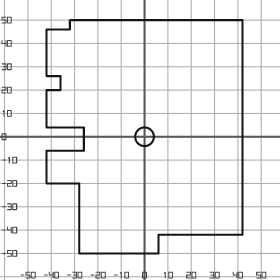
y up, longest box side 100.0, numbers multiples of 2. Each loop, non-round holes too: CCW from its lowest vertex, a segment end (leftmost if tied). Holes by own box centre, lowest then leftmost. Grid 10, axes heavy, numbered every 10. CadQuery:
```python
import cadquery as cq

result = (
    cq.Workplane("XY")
    .moveTo(-28.0, -50.0)
    .lineTo(6.0, -50.0)
    .lineTo(6.0, -42.0)
    .lineTo(42.0, -42.0)
    .lineTo(42.0, 50.0)
    .lineTo(-32.0, 50.0)
    .lineTo(-32.0, 46.0)
    .lineTo(-42.0, 46.0)
    .lineTo(-42.0, 26.0)
    .lineTo(-36.0, 26.0)
    .lineTo(-36.0, 20.0)
    .lineTo(-42.0, 20.0)
    .lineTo(-42.0, 4.0)
    .lineTo(-26.0, 4.0)
    .lineTo(-26.0, -6.0)
    .lineTo(-42.0, -6.0)
    .lineTo(-42.0, -20.0)
    .lineTo(-28.0, -20.0)
    .close()
    .moveTo(0.0, 0.0)
    .circle(4.0)
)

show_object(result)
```